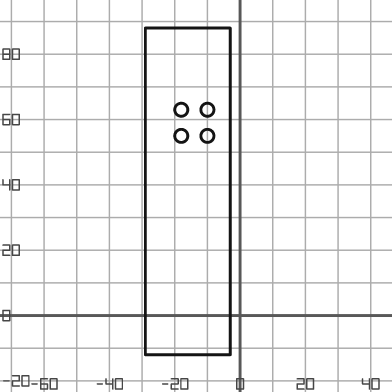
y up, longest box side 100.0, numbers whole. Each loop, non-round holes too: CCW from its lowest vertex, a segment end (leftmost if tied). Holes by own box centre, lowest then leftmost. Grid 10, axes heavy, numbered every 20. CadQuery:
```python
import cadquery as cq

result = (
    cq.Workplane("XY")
    .moveTo(-29.0, -12.0)
    .lineTo(-3.0, -12.0)
    .lineTo(-3.0, 88.0)
    .lineTo(-29.0, 88.0)
    .close()
    .moveTo(-18.0, 55.0)
    .circle(2.0)
    .moveTo(-10.0, 55.0)
    .circle(2.0)
    .moveTo(-18.0, 63.0)
    .circle(2.0)
    .moveTo(-10.0, 63.0)
    .circle(2.0)
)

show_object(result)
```